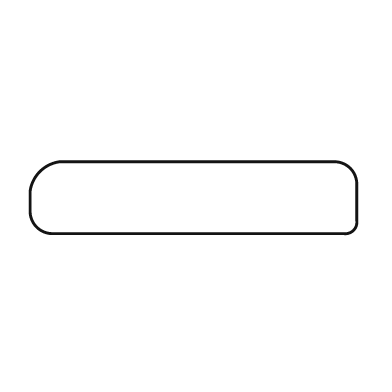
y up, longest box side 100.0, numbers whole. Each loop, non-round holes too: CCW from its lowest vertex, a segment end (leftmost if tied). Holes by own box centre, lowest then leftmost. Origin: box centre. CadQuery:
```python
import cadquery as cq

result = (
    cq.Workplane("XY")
    .moveTo(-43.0, -11.0)
    .lineTo(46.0, -11.0)
    .threePointArc((49.0, -10.0), (50.0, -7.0))
    .lineTo(50.0, 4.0)
    .threePointArc((48.0, 9.0), (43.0, 11.0))
    .lineTo(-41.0, 11.0)
    .threePointArc((-47.0, 8.0), (-50.0, 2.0))
    .lineTo(-50.0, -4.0)
    .threePointArc((-48.0, -9.0), (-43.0, -11.0))
    .close()
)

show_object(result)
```